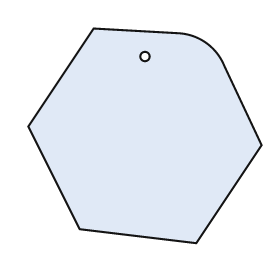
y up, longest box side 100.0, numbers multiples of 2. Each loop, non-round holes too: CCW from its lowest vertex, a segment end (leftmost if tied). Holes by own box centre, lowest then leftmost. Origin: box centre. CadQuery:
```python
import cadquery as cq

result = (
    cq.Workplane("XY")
    .moveTo(22.0, -46.0)
    .lineTo(50.0, -4.0)
    .lineTo(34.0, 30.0)
    .threePointArc((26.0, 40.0), (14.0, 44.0))
    .lineTo(-22.0, 46.0)
    .lineTo(-50.0, 4.0)
    .lineTo(-28.0, -40.0)
    .close()
    .moveTo(0.0, 34.0)
    .circle(2.0)
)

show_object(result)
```